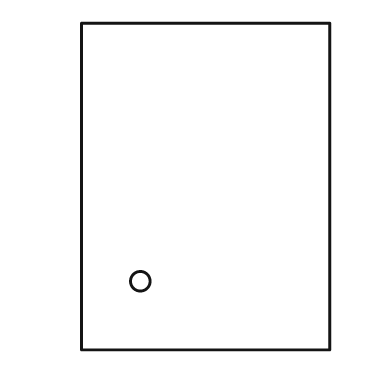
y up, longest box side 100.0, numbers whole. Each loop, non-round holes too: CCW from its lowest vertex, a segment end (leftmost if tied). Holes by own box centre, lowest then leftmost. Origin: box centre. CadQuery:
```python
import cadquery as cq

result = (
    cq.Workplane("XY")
    .moveTo(-38.0, -50.0)
    .lineTo(38.0, -50.0)
    .lineTo(38.0, 50.0)
    .lineTo(-38.0, 50.0)
    .close()
    .moveTo(-20.0, -29.0)
    .circle(3.0)
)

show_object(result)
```